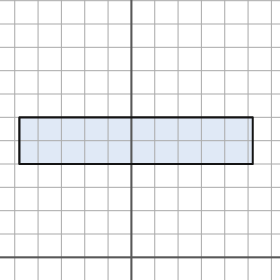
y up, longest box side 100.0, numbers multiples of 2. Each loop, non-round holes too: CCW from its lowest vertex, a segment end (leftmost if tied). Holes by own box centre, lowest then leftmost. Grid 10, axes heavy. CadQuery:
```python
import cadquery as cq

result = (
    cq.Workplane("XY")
    .moveTo(-48.0, 40.0)
    .lineTo(52.0, 40.0)
    .lineTo(52.0, 60.0)
    .lineTo(-48.0, 60.0)
    .close()
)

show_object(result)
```